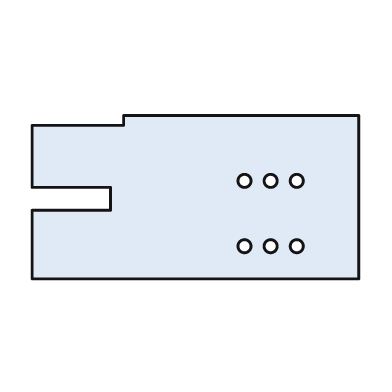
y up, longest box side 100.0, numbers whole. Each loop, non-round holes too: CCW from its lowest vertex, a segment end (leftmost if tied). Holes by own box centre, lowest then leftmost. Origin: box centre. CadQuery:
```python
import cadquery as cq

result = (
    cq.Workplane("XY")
    .moveTo(-50.0, -25.0)
    .lineTo(50.0, -25.0)
    .lineTo(50.0, 25.0)
    .lineTo(-22.0, 25.0)
    .lineTo(-22.0, 22.0)
    .lineTo(-50.0, 22.0)
    .lineTo(-50.0, 3.0)
    .lineTo(-26.0, 3.0)
    .lineTo(-26.0, -4.0)
    .lineTo(-50.0, -4.0)
    .close()
    .moveTo(15.0, -15.0)
    .circle(2.0)
    .moveTo(23.0, -15.0)
    .circle(2.0)
    .moveTo(31.0, -15.0)
    .circle(2.0)
    .moveTo(15.0, 5.0)
    .circle(2.0)
    .moveTo(23.0, 5.0)
    .circle(2.0)
    .moveTo(31.0, 5.0)
    .circle(2.0)
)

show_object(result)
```